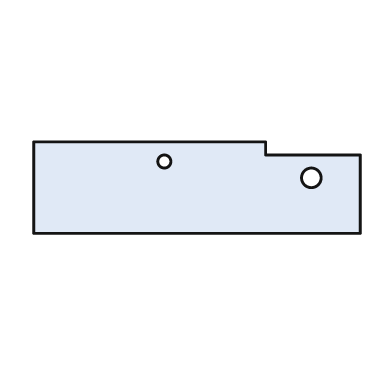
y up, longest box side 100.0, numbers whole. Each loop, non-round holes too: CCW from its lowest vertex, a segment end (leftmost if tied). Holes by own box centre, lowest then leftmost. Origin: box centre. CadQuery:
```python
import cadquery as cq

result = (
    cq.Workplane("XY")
    .moveTo(-50.0, -14.0)
    .lineTo(50.0, -14.0)
    .lineTo(50.0, 10.0)
    .lineTo(21.0, 10.0)
    .lineTo(21.0, 14.0)
    .lineTo(-50.0, 14.0)
    .close()
    .moveTo(35.0, 3.0)
    .circle(3.0)
    .moveTo(-10.0, 8.0)
    .circle(2.0)
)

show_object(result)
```